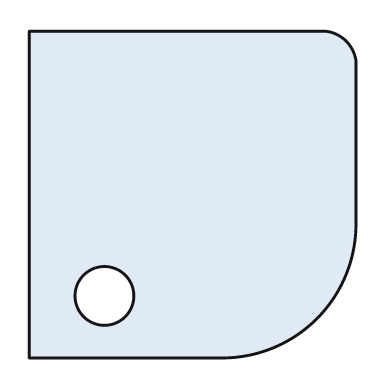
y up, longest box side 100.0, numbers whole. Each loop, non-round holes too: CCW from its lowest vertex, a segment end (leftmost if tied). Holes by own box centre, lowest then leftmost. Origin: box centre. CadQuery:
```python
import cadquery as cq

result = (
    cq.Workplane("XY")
    .moveTo(-50.0, -50.0)
    .lineTo(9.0, -50.0)
    .threePointArc((38.0, -38.0), (50.0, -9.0))
    .lineTo(50.0, 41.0)
    .threePointArc((47.0, 47.0), (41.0, 50.0))
    .lineTo(-50.0, 50.0)
    .close()
    .moveTo(-27.0, -31.0)
    .circle(9.0)
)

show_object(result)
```